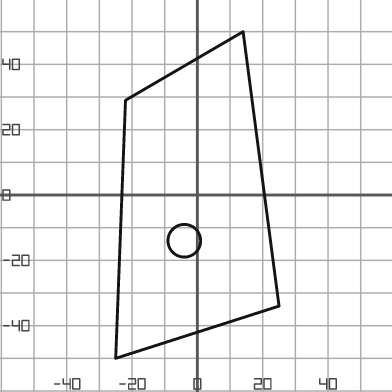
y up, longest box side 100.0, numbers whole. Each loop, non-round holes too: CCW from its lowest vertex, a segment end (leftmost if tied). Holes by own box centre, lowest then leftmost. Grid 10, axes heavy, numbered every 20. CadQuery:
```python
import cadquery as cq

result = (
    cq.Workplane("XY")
    .moveTo(-25.0, -50.0)
    .lineTo(25.0, -34.0)
    .lineTo(14.0, 50.0)
    .lineTo(-22.0, 29.0)
    .close()
    .moveTo(-4.0, -14.0)
    .circle(5.0)
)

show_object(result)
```